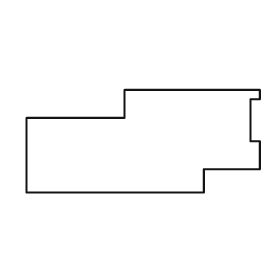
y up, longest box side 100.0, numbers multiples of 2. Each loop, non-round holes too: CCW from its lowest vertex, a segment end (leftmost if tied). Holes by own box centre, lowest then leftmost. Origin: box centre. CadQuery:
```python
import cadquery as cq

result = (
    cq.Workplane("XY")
    .moveTo(-50.0, -22.0)
    .lineTo(26.0, -22.0)
    .lineTo(26.0, -12.0)
    .lineTo(50.0, -12.0)
    .lineTo(50.0, 0.0)
    .lineTo(46.0, 0.0)
    .lineTo(46.0, 18.0)
    .lineTo(50.0, 18.0)
    .lineTo(50.0, 22.0)
    .lineTo(-8.0, 22.0)
    .lineTo(-8.0, 10.0)
    .lineTo(-50.0, 10.0)
    .close()
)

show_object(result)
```